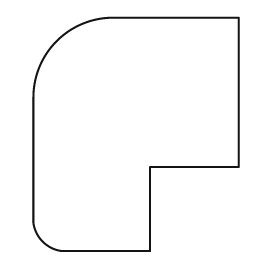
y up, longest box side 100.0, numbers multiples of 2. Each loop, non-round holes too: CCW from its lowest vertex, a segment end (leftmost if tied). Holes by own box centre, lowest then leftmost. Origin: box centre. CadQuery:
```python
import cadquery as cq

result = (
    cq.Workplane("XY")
    .moveTo(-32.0, -50.0)
    .lineTo(6.0, -50.0)
    .lineTo(6.0, -14.0)
    .lineTo(44.0, -14.0)
    .lineTo(44.0, 50.0)
    .lineTo(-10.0, 50.0)
    .threePointArc((-34.0, 40.0), (-44.0, 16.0))
    .lineTo(-44.0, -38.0)
    .threePointArc((-40.0, -46.0), (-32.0, -50.0))
    .close()
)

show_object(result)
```